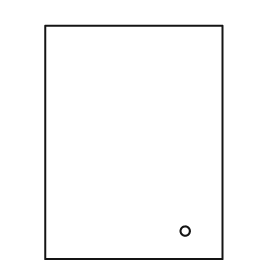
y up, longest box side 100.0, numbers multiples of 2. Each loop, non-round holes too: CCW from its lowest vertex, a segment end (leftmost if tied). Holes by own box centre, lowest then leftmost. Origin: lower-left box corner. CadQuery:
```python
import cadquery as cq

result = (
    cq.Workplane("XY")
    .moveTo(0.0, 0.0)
    .lineTo(76.0, 0.0)
    .lineTo(76.0, 100.0)
    .lineTo(0.0, 100.0)
    .close()
    .moveTo(60.0, 12.0)
    .circle(2.0)
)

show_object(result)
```